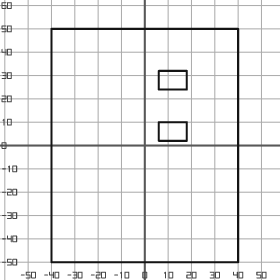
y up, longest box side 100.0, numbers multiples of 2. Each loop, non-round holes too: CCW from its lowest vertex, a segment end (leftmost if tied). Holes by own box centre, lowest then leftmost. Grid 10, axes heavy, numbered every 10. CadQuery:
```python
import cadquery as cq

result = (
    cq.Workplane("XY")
    .moveTo(-40.0, -50.0)
    .lineTo(40.0, -50.0)
    .lineTo(40.0, 50.0)
    .lineTo(-40.0, 50.0)
    .close()
    .moveTo(6.0, 2.0)
    .lineTo(18.0, 2.0)
    .lineTo(18.0, 10.0)
    .lineTo(6.0, 10.0)
    .close()
    .moveTo(6.0, 24.0)
    .lineTo(18.0, 24.0)
    .lineTo(18.0, 32.0)
    .lineTo(6.0, 32.0)
    .close()
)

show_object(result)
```